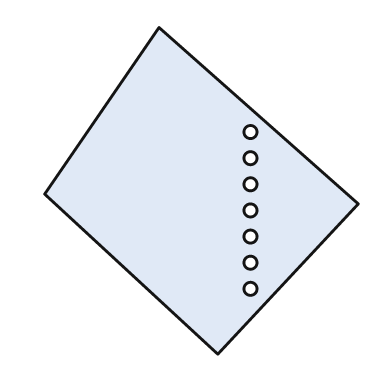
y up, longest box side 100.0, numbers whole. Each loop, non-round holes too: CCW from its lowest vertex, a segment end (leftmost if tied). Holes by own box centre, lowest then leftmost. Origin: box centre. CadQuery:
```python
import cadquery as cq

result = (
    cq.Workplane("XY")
    .moveTo(5.0, -50.0)
    .lineTo(48.0, -4.0)
    .lineTo(-13.0, 50.0)
    .lineTo(-48.0, -1.0)
    .close()
    .moveTo(15.0, -30.0)
    .circle(2.0)
    .moveTo(15.0, -22.0)
    .circle(2.0)
    .moveTo(15.0, -14.0)
    .circle(2.0)
    .moveTo(15.0, -6.0)
    .circle(2.0)
    .moveTo(15.0, 2.0)
    .circle(2.0)
    .moveTo(15.0, 10.0)
    .circle(2.0)
    .moveTo(15.0, 18.0)
    .circle(2.0)
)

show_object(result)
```